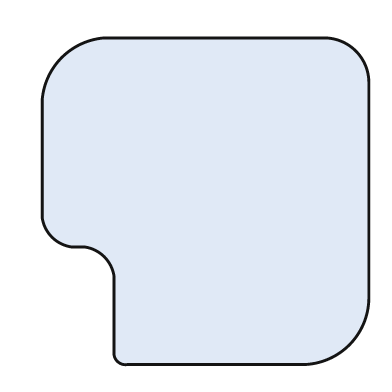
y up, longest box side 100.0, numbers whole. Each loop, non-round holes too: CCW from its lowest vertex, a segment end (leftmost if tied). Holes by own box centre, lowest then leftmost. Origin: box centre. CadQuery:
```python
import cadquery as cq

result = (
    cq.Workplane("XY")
    .moveTo(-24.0, -50.0)
    .lineTo(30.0, -50.0)
    .threePointArc((44.0, -44.0), (50.0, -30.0))
    .lineTo(50.0, 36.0)
    .threePointArc((46.0, 46.0), (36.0, 50.0))
    .lineTo(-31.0, 50.0)
    .threePointArc((-44.0, 44.0), (-50.0, 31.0))
    .lineTo(-50.0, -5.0)
    .threePointArc((-47.0, -11.0), (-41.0, -14.0))
    .lineTo(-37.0, -14.0)
    .threePointArc((-31.0, -17.0), (-28.0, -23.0))
    .lineTo(-28.0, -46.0)
    .threePointArc((-27.0, -49.0), (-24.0, -50.0))
    .close()
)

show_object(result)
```